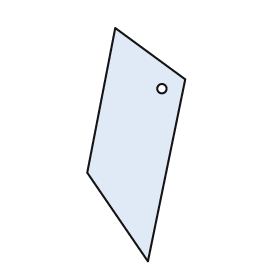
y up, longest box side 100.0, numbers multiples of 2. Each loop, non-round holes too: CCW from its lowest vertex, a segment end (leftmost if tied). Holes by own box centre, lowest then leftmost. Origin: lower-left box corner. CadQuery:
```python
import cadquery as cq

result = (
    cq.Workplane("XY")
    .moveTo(26.0, 0.0)
    .lineTo(42.0, 78.0)
    .lineTo(12.0, 100.0)
    .lineTo(0.0, 38.0)
    .close()
    .moveTo(32.0, 74.0)
    .circle(2.0)
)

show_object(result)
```